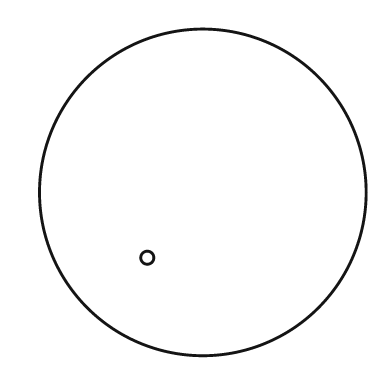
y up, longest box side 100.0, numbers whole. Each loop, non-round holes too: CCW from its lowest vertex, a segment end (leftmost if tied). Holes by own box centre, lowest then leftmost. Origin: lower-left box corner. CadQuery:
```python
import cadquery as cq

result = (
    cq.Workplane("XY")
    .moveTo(50.0, 50.0)
    .circle(50.0)
    .moveTo(33.0, 30.0)
    .circle(2.0)
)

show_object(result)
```